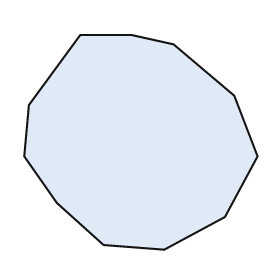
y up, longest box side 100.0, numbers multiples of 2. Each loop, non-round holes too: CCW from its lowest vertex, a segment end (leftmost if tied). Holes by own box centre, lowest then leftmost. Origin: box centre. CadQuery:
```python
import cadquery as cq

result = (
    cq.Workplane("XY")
    .moveTo(10.0, -46.0)
    .lineTo(36.0, -32.0)
    .lineTo(50.0, -6.0)
    .lineTo(40.0, 20.0)
    .lineTo(14.0, 42.0)
    .lineTo(-4.0, 46.0)
    .lineTo(-26.0, 46.0)
    .lineTo(-48.0, 16.0)
    .lineTo(-50.0, -6.0)
    .lineTo(-36.0, -26.0)
    .lineTo(-16.0, -44.0)
    .close()
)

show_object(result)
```